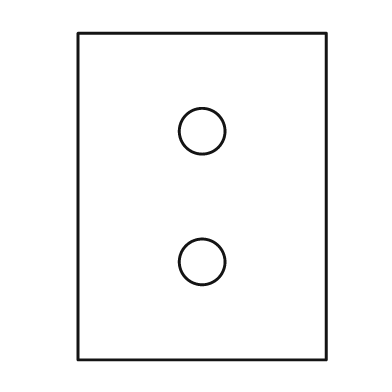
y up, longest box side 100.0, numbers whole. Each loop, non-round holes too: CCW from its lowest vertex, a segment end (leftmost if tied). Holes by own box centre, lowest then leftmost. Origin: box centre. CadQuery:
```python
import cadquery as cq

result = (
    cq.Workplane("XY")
    .moveTo(-38.0, -50.0)
    .lineTo(38.0, -50.0)
    .lineTo(38.0, 50.0)
    .lineTo(-38.0, 50.0)
    .close()
    .moveTo(0.0, -20.0)
    .circle(7.0)
    .moveTo(0.0, 20.0)
    .circle(7.0)
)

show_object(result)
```